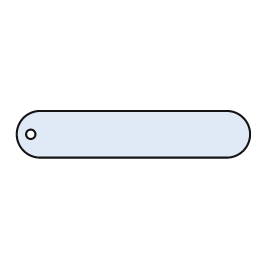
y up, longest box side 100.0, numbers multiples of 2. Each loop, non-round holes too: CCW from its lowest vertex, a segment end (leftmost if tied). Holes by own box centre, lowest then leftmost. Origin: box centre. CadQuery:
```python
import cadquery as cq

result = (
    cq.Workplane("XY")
    .moveTo(-40.0, -10.0)
    .lineTo(40.0, -10.0)
    .threePointArc((50.0, 0.0), (40.0, 10.0))
    .lineTo(-40.0, 10.0)
    .threePointArc((-50.0, 0.0), (-40.0, -10.0))
    .close()
    .moveTo(-44.0, 0.0)
    .circle(2.0)
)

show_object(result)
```